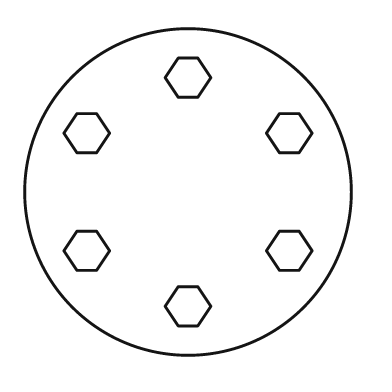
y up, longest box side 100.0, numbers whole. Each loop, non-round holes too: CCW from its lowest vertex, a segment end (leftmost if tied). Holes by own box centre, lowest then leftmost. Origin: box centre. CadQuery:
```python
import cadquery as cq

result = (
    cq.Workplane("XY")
    .moveTo(0.0, 0.0)
    .circle(50.0)
    .moveTo(-3.0, -41.0)
    .lineTo(3.0, -41.0)
    .lineTo(7.0, -35.0)
    .lineTo(3.0, -29.0)
    .lineTo(-3.0, -29.0)
    .lineTo(-7.0, -35.0)
    .close()
    .moveTo(-34.0, -24.0)
    .lineTo(-28.0, -24.0)
    .lineTo(-24.0, -18.0)
    .lineTo(-28.0, -12.0)
    .lineTo(-34.0, -12.0)
    .lineTo(-38.0, -18.0)
    .close()
    .moveTo(28.0, -24.0)
    .lineTo(34.0, -24.0)
    .lineTo(38.0, -18.0)
    .lineTo(34.0, -12.0)
    .lineTo(28.0, -12.0)
    .lineTo(24.0, -18.0)
    .close()
    .moveTo(-34.0, 12.0)
    .lineTo(-28.0, 12.0)
    .lineTo(-24.0, 18.0)
    .lineTo(-28.0, 24.0)
    .lineTo(-34.0, 24.0)
    .lineTo(-38.0, 18.0)
    .close()
    .moveTo(28.0, 12.0)
    .lineTo(34.0, 12.0)
    .lineTo(38.0, 18.0)
    .lineTo(34.0, 24.0)
    .lineTo(28.0, 24.0)
    .lineTo(24.0, 18.0)
    .close()
    .moveTo(-3.0, 29.0)
    .lineTo(3.0, 29.0)
    .lineTo(7.0, 35.0)
    .lineTo(3.0, 41.0)
    .lineTo(-3.0, 41.0)
    .lineTo(-7.0, 35.0)
    .close()
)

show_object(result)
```